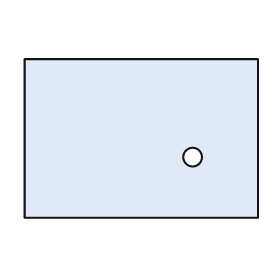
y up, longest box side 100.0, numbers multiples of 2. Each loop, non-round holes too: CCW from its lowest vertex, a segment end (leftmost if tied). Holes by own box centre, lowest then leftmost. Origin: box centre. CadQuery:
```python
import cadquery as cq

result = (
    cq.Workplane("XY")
    .moveTo(-50.0, -34.0)
    .lineTo(50.0, -34.0)
    .lineTo(50.0, 34.0)
    .lineTo(-50.0, 34.0)
    .close()
    .moveTo(22.0, -8.0)
    .circle(4.0)
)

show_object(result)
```